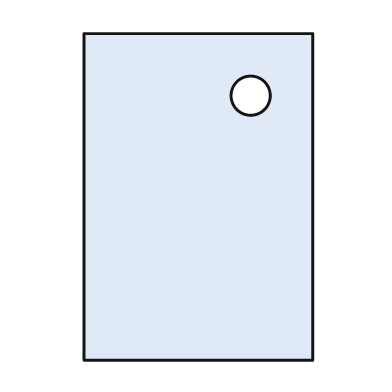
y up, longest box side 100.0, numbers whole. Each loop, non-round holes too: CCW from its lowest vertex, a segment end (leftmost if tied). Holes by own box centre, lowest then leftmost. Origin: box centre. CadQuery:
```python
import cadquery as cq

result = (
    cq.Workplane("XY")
    .moveTo(-35.0, -50.0)
    .lineTo(35.0, -50.0)
    .lineTo(35.0, 50.0)
    .lineTo(-35.0, 50.0)
    .close()
    .moveTo(16.0, 31.0)
    .circle(6.0)
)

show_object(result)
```